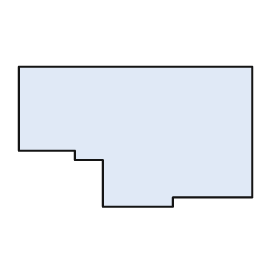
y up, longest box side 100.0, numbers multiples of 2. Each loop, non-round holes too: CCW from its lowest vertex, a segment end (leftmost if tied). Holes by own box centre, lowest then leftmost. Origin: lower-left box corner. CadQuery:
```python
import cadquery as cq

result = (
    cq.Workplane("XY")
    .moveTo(36.0, 0.0)
    .lineTo(66.0, 0.0)
    .lineTo(66.0, 4.0)
    .lineTo(100.0, 4.0)
    .lineTo(100.0, 60.0)
    .lineTo(0.0, 60.0)
    .lineTo(0.0, 24.0)
    .lineTo(24.0, 24.0)
    .lineTo(24.0, 20.0)
    .lineTo(36.0, 20.0)
    .close()
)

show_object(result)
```